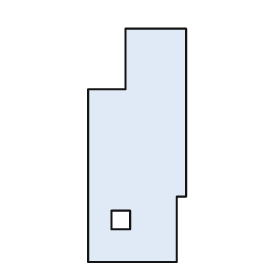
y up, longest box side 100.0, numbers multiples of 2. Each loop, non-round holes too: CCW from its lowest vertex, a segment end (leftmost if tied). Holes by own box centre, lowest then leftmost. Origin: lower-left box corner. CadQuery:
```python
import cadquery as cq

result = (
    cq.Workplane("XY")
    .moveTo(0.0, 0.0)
    .lineTo(38.0, 0.0)
    .lineTo(38.0, 28.0)
    .lineTo(42.0, 28.0)
    .lineTo(42.0, 100.0)
    .lineTo(16.0, 100.0)
    .lineTo(16.0, 74.0)
    .lineTo(0.0, 74.0)
    .close()
    .moveTo(10.0, 14.0)
    .lineTo(18.0, 14.0)
    .lineTo(18.0, 22.0)
    .lineTo(10.0, 22.0)
    .close()
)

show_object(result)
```